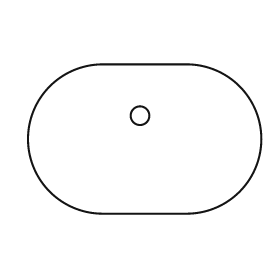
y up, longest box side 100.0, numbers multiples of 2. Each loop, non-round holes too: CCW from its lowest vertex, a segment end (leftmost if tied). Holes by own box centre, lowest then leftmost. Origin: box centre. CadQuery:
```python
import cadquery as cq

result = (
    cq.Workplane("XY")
    .moveTo(-18.0, -32.0)
    .lineTo(18.0, -32.0)
    .threePointArc((50.0, 0.0), (18.0, 32.0))
    .lineTo(-18.0, 32.0)
    .threePointArc((-50.0, 0.0), (-18.0, -32.0))
    .close()
    .moveTo(-2.0, 10.0)
    .circle(4.0)
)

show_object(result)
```